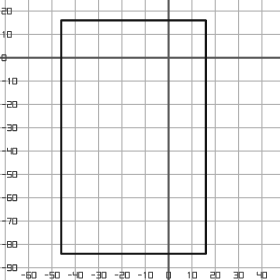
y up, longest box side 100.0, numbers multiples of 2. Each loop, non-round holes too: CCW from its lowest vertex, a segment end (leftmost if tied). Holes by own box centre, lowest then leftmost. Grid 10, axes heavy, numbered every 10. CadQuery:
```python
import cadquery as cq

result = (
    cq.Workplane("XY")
    .moveTo(-46.0, -84.0)
    .lineTo(16.0, -84.0)
    .lineTo(16.0, 16.0)
    .lineTo(-46.0, 16.0)
    .close()
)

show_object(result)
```